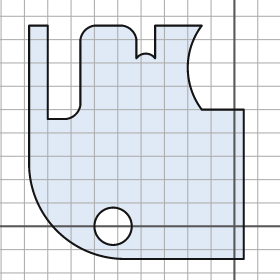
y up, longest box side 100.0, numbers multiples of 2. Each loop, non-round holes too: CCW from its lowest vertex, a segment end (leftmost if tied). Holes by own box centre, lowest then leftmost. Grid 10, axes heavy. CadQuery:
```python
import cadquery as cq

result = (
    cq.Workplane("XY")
    .moveTo(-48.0, -14.0)
    .lineTo(4.0, -14.0)
    .lineTo(4.0, 50.0)
    .lineTo(-14.0, 50.0)
    .threePointArc((-20.0, 68.0), (-14.0, 86.0))
    .lineTo(-34.0, 86.0)
    .lineTo(-34.0, 72.0)
    .threePointArc((-38.0, 74.0), (-42.0, 72.0))
    .lineTo(-42.0, 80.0)
    .threePointArc((-44.0, 84.0), (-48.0, 86.0))
    .lineTo(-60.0, 86.0)
    .threePointArc((-64.0, 84.0), (-66.0, 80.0))
    .lineTo(-66.0, 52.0)
    .threePointArc((-68.0, 48.0), (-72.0, 46.0))
    .lineTo(-80.0, 46.0)
    .lineTo(-80.0, 86.0)
    .lineTo(-88.0, 86.0)
    .lineTo(-88.0, 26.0)
    .threePointArc((-76.0, -2.0), (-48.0, -14.0))
    .close()
    .moveTo(-52.0, 0.0)
    .circle(8.0)
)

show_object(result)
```